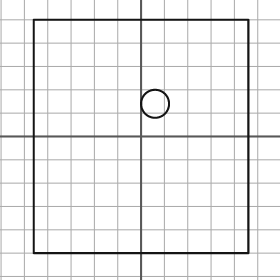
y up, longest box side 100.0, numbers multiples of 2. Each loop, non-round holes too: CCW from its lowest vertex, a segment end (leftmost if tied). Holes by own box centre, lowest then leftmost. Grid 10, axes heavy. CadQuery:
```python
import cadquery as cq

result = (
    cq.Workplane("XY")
    .moveTo(-46.0, -50.0)
    .lineTo(46.0, -50.0)
    .lineTo(46.0, 50.0)
    .lineTo(-46.0, 50.0)
    .close()
    .moveTo(6.0, 14.0)
    .circle(6.0)
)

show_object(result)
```